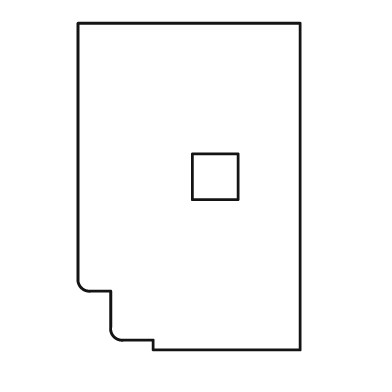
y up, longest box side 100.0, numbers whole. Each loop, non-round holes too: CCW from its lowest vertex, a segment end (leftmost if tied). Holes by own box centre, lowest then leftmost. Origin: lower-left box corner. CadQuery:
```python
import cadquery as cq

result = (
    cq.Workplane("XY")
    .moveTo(23.0, 0.0)
    .lineTo(68.0, 0.0)
    .lineTo(68.0, 100.0)
    .lineTo(0.0, 100.0)
    .lineTo(0.0, 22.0)
    .threePointArc((1.0, 19.0), (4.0, 18.0))
    .lineTo(10.0, 18.0)
    .lineTo(10.0, 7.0)
    .threePointArc((11.0, 4.0), (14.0, 3.0))
    .lineTo(23.0, 3.0)
    .close()
    .moveTo(35.0, 46.0)
    .lineTo(49.0, 46.0)
    .lineTo(49.0, 60.0)
    .lineTo(35.0, 60.0)
    .close()
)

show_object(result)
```